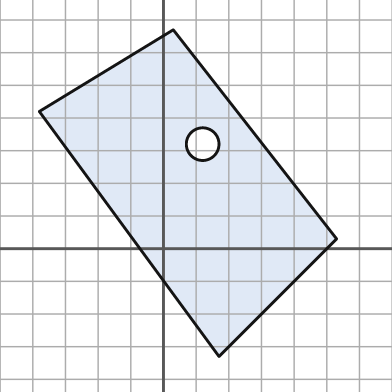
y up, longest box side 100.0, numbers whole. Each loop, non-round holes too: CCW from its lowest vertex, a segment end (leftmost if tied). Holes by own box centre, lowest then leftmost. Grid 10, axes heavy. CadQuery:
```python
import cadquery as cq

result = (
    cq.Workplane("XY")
    .moveTo(17.0, -33.0)
    .lineTo(53.0, 3.0)
    .lineTo(3.0, 67.0)
    .lineTo(-38.0, 42.0)
    .close()
    .moveTo(12.0, 32.0)
    .circle(5.0)
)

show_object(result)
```